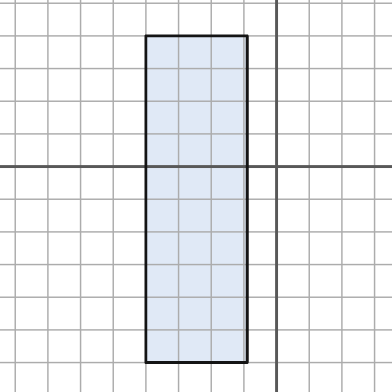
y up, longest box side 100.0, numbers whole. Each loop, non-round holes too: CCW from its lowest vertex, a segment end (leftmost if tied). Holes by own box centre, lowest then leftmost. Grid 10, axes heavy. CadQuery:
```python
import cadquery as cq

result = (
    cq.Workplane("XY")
    .moveTo(-40.0, -60.0)
    .lineTo(-9.0, -60.0)
    .lineTo(-9.0, 40.0)
    .lineTo(-40.0, 40.0)
    .close()
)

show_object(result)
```